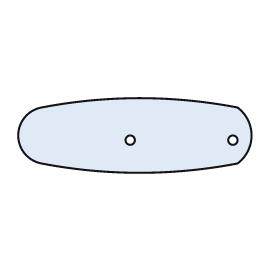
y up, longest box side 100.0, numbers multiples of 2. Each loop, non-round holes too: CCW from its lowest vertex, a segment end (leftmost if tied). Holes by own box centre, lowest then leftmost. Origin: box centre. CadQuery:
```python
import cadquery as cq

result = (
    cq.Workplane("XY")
    .moveTo(-40.0, -12.0)
    .threePointArc((2.0, -16.0), (44.0, -12.0))
    .threePointArc((50.0, 0.0), (44.0, 12.0))
    .threePointArc((2.0, 16.0), (-40.0, 12.0))
    .threePointArc((-50.0, 0.0), (-40.0, -12.0))
    .close()
    .moveTo(-2.0, -2.0)
    .circle(2.0)
    .moveTo(42.0, -2.0)
    .circle(2.0)
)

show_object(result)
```